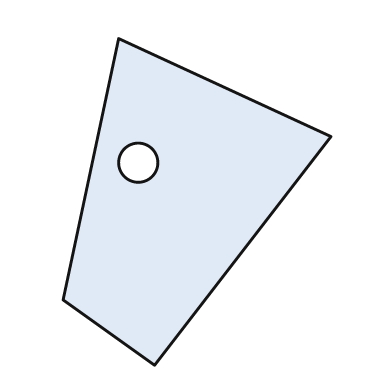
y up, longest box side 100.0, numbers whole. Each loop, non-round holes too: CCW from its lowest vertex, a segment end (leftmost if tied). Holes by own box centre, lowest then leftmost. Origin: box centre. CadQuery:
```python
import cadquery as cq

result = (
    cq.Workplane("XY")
    .moveTo(-13.0, -50.0)
    .lineTo(41.0, 20.0)
    .lineTo(-24.0, 50.0)
    .lineTo(-41.0, -30.0)
    .close()
    .moveTo(-18.0, 12.0)
    .circle(6.0)
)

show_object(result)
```